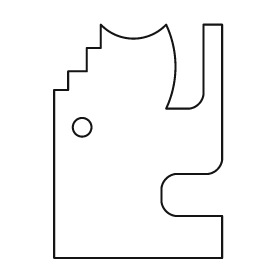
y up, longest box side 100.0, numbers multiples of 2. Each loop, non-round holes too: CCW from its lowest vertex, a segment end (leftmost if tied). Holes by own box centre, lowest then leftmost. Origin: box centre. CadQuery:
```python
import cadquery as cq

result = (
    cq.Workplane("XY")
    .moveTo(-36.0, -50.0)
    .lineTo(36.0, -50.0)
    .lineTo(36.0, -32.0)
    .lineTo(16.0, -32.0)
    .threePointArc((12.0, -30.0), (10.0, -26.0))
    .lineTo(10.0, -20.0)
    .threePointArc((12.0, -16.0), (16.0, -14.0))
    .lineTo(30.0, -14.0)
    .threePointArc((34.0, -12.0), (36.0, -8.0))
    .lineTo(36.0, 50.0)
    .lineTo(28.0, 50.0)
    .lineTo(28.0, 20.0)
    .threePointArc((26.0, 16.0), (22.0, 14.0))
    .lineTo(12.0, 14.0)
    .threePointArc((16.0, 32.0), (12.0, 50.0))
    .threePointArc((-2.0, 44.0), (-16.0, 50.0))
    .lineTo(-16.0, 40.0)
    .lineTo(-22.0, 40.0)
    .lineTo(-22.0, 30.0)
    .lineTo(-30.0, 30.0)
    .lineTo(-30.0, 22.0)
    .lineTo(-36.0, 22.0)
    .close()
    .moveTo(-24.0, 6.0)
    .circle(4.0)
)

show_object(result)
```